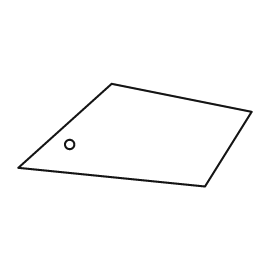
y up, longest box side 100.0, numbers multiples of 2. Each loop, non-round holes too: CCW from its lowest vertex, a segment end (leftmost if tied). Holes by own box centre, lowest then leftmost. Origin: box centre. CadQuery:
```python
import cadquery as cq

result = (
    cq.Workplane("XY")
    .moveTo(30.0, -22.0)
    .lineTo(50.0, 10.0)
    .lineTo(-10.0, 22.0)
    .lineTo(-50.0, -14.0)
    .close()
    .moveTo(-28.0, -4.0)
    .circle(2.0)
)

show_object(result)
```